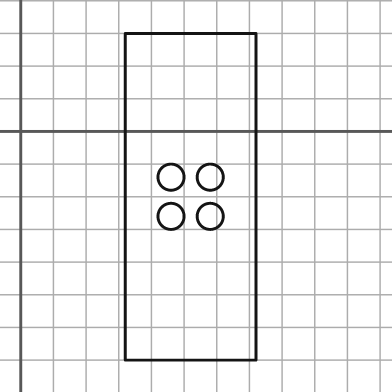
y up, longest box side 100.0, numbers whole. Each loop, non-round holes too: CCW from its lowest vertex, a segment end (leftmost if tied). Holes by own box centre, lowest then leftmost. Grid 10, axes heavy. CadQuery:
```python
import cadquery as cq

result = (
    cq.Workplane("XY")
    .moveTo(32.0, -70.0)
    .lineTo(72.0, -70.0)
    .lineTo(72.0, 30.0)
    .lineTo(32.0, 30.0)
    .close()
    .moveTo(46.0, -26.0)
    .circle(4.0)
    .moveTo(58.0, -26.0)
    .circle(4.0)
    .moveTo(46.0, -14.0)
    .circle(4.0)
    .moveTo(58.0, -14.0)
    .circle(4.0)
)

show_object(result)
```